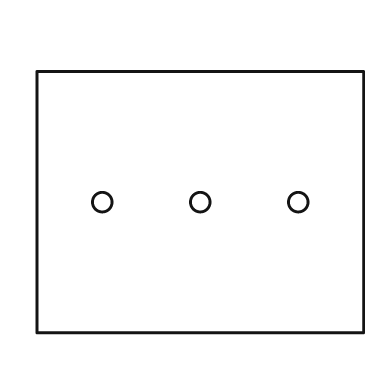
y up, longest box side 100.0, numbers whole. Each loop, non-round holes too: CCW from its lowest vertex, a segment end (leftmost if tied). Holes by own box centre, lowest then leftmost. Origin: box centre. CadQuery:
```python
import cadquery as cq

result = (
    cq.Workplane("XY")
    .moveTo(-50.0, -40.0)
    .lineTo(50.0, -40.0)
    .lineTo(50.0, 40.0)
    .lineTo(-50.0, 40.0)
    .close()
    .moveTo(-30.0, 0.0)
    .circle(3.0)
    .moveTo(0.0, 0.0)
    .circle(3.0)
    .moveTo(30.0, 0.0)
    .circle(3.0)
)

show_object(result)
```